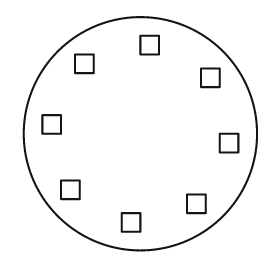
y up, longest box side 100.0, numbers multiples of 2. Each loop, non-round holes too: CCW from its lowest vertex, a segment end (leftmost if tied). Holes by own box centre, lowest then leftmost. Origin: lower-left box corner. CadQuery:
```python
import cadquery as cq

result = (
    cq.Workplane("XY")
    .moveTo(50.0, 50.0)
    .circle(50.0)
    .moveTo(42.0, 8.0)
    .lineTo(50.0, 8.0)
    .lineTo(50.0, 16.0)
    .lineTo(42.0, 16.0)
    .close()
    .moveTo(70.0, 16.0)
    .lineTo(78.0, 16.0)
    .lineTo(78.0, 24.0)
    .lineTo(70.0, 24.0)
    .close()
    .moveTo(16.0, 22.0)
    .lineTo(24.0, 22.0)
    .lineTo(24.0, 30.0)
    .lineTo(16.0, 30.0)
    .close()
    .moveTo(84.0, 42.0)
    .lineTo(92.0, 42.0)
    .lineTo(92.0, 50.0)
    .lineTo(84.0, 50.0)
    .close()
    .moveTo(8.0, 50.0)
    .lineTo(16.0, 50.0)
    .lineTo(16.0, 58.0)
    .lineTo(8.0, 58.0)
    .close()
    .moveTo(76.0, 70.0)
    .lineTo(84.0, 70.0)
    .lineTo(84.0, 78.0)
    .lineTo(76.0, 78.0)
    .close()
    .moveTo(22.0, 76.0)
    .lineTo(30.0, 76.0)
    .lineTo(30.0, 84.0)
    .lineTo(22.0, 84.0)
    .close()
    .moveTo(50.0, 84.0)
    .lineTo(58.0, 84.0)
    .lineTo(58.0, 92.0)
    .lineTo(50.0, 92.0)
    .close()
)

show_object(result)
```